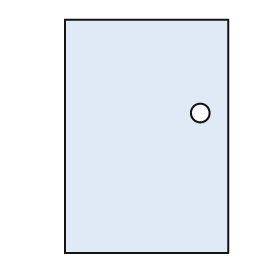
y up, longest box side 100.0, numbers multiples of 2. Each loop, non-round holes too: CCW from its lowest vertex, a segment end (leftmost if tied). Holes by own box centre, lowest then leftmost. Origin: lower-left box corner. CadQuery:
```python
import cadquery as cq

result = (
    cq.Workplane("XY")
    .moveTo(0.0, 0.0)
    .lineTo(70.0, 0.0)
    .lineTo(70.0, 100.0)
    .lineTo(0.0, 100.0)
    .close()
    .moveTo(58.0, 60.0)
    .circle(4.0)
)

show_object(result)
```